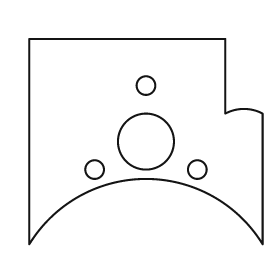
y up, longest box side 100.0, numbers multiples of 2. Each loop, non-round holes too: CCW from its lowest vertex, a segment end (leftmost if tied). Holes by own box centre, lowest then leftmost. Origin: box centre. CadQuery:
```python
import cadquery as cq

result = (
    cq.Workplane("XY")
    .moveTo(-50.0, -44.0)
    .threePointArc((0.0, -16.0), (50.0, -44.0))
    .lineTo(50.0, 12.0)
    .threePointArc((42.0, 14.0), (34.0, 12.0))
    .lineTo(34.0, 44.0)
    .lineTo(-50.0, 44.0)
    .close()
    .moveTo(-22.0, -12.0)
    .circle(4.0)
    .moveTo(22.0, -12.0)
    .circle(4.0)
    .moveTo(0.0, 0.0)
    .circle(12.0)
    .moveTo(0.0, 24.0)
    .circle(4.0)
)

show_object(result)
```